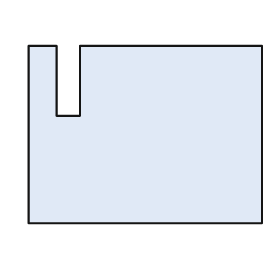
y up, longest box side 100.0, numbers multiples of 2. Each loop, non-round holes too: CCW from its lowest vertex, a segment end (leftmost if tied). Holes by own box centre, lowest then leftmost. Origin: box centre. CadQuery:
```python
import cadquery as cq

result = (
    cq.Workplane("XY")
    .moveTo(-50.0, -38.0)
    .lineTo(50.0, -38.0)
    .lineTo(50.0, 38.0)
    .lineTo(-28.0, 38.0)
    .lineTo(-28.0, 8.0)
    .lineTo(-38.0, 8.0)
    .lineTo(-38.0, 38.0)
    .lineTo(-50.0, 38.0)
    .close()
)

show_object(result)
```